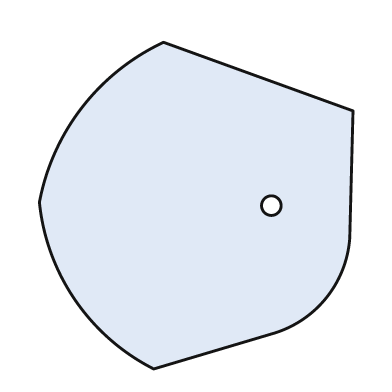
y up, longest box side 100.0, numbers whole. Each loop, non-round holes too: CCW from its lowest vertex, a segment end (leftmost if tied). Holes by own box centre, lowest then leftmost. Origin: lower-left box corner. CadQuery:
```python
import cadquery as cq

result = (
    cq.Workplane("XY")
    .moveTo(35.0, 0.0)
    .lineTo(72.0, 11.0)
    .threePointArc((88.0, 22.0), (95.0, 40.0))
    .lineTo(96.0, 79.0)
    .lineTo(38.0, 100.0)
    .threePointArc((13.0, 80.0), (0.0, 51.0))
    .threePointArc((11.0, 21.0), (35.0, 0.0))
    .close()
    .moveTo(71.0, 50.0)
    .circle(3.0)
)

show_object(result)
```